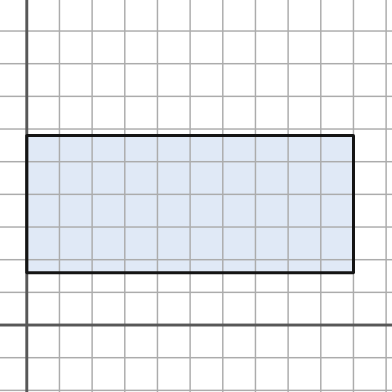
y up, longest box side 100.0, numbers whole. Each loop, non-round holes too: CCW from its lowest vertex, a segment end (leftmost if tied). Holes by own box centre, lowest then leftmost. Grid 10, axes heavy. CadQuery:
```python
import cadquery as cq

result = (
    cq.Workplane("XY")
    .moveTo(0.0, 16.0)
    .lineTo(100.0, 16.0)
    .lineTo(100.0, 58.0)
    .lineTo(0.0, 58.0)
    .close()
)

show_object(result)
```